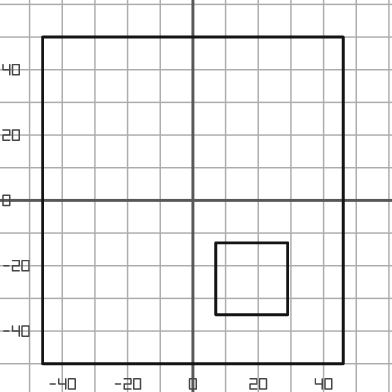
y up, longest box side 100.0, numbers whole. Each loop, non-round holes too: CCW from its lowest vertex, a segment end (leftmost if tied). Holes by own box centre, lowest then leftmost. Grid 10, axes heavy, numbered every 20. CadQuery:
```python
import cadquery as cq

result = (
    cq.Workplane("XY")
    .moveTo(-46.0, -50.0)
    .lineTo(46.0, -50.0)
    .lineTo(46.0, 50.0)
    .lineTo(-46.0, 50.0)
    .close()
    .moveTo(7.0, -35.0)
    .lineTo(29.0, -35.0)
    .lineTo(29.0, -13.0)
    .lineTo(7.0, -13.0)
    .close()
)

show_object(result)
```